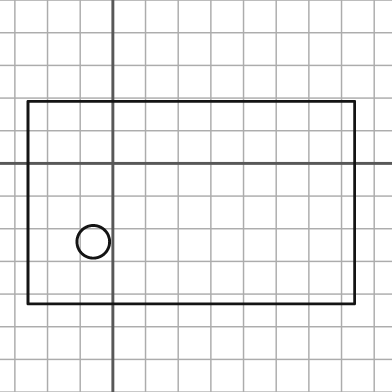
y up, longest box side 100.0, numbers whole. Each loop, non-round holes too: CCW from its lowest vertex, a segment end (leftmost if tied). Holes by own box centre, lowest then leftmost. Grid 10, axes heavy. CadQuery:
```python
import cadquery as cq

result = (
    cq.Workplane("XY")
    .moveTo(-26.0, -43.0)
    .lineTo(74.0, -43.0)
    .lineTo(74.0, 19.0)
    .lineTo(-26.0, 19.0)
    .close()
    .moveTo(-6.0, -24.0)
    .circle(5.0)
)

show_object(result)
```